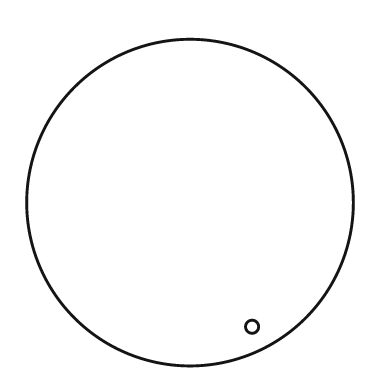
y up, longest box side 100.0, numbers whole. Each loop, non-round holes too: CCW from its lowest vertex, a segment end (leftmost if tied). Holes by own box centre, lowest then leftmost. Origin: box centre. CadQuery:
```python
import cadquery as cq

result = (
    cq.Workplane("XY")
    .moveTo(0.0, 0.0)
    .circle(50.0)
    .moveTo(19.0, -38.0)
    .circle(2.0)
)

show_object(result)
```